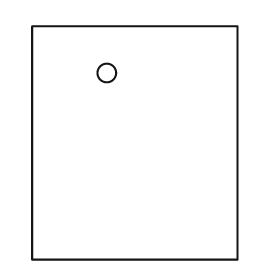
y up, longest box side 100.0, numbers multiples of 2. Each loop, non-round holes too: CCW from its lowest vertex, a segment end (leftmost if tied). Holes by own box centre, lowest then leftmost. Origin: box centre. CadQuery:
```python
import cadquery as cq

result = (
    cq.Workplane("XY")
    .moveTo(-44.0, -50.0)
    .lineTo(44.0, -50.0)
    .lineTo(44.0, 50.0)
    .lineTo(-44.0, 50.0)
    .close()
    .moveTo(-12.0, 30.0)
    .circle(4.0)
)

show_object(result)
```